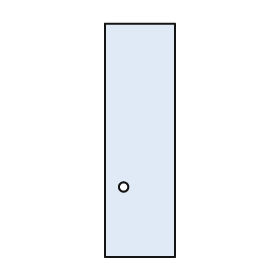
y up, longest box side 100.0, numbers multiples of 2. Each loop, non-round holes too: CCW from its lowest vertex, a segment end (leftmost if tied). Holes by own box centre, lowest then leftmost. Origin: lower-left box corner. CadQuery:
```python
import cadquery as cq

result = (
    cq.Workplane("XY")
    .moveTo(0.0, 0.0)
    .lineTo(30.0, 0.0)
    .lineTo(30.0, 100.0)
    .lineTo(0.0, 100.0)
    .close()
    .moveTo(8.0, 30.0)
    .circle(2.0)
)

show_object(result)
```